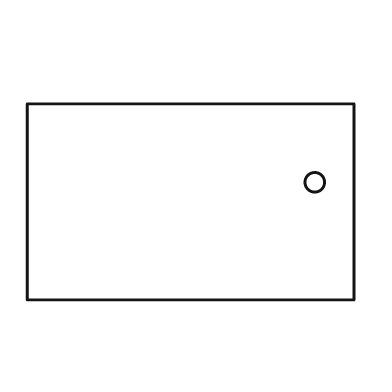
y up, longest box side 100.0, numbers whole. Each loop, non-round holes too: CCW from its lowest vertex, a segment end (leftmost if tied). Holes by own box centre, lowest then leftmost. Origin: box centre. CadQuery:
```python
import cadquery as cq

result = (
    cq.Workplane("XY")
    .moveTo(-50.0, -30.0)
    .lineTo(50.0, -30.0)
    .lineTo(50.0, 30.0)
    .lineTo(-50.0, 30.0)
    .close()
    .moveTo(38.0, 6.0)
    .circle(3.0)
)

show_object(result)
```